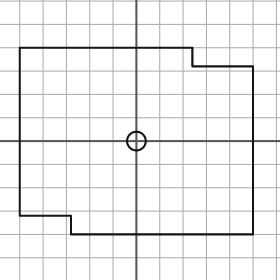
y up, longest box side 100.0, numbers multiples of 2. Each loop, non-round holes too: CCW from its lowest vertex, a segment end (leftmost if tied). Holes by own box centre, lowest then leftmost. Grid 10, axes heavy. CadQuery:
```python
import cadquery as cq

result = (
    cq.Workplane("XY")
    .moveTo(-28.0, -40.0)
    .lineTo(50.0, -40.0)
    .lineTo(50.0, 32.0)
    .lineTo(24.0, 32.0)
    .lineTo(24.0, 40.0)
    .lineTo(-50.0, 40.0)
    .lineTo(-50.0, -32.0)
    .lineTo(-28.0, -32.0)
    .close()
    .moveTo(0.0, 0.0)
    .circle(4.0)
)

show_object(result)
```